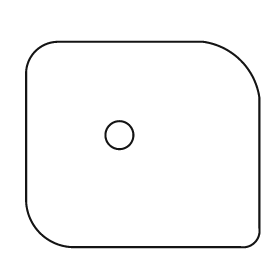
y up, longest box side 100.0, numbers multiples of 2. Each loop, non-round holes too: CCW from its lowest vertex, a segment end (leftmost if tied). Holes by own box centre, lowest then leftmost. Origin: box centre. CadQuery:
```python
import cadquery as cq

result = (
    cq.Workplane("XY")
    .moveTo(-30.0, -44.0)
    .lineTo(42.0, -44.0)
    .threePointArc((48.0, -42.0), (50.0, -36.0))
    .lineTo(50.0, 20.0)
    .threePointArc((42.0, 36.0), (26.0, 44.0))
    .lineTo(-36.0, 44.0)
    .threePointArc((-46.0, 40.0), (-50.0, 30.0))
    .lineTo(-50.0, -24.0)
    .threePointArc((-44.0, -38.0), (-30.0, -44.0))
    .close()
    .moveTo(-10.0, 4.0)
    .circle(6.0)
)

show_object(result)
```